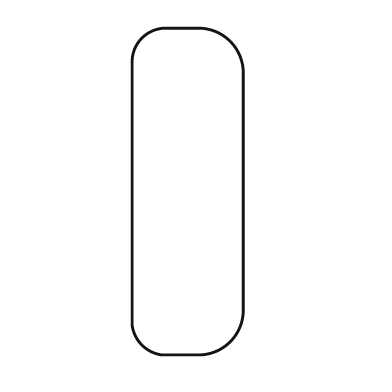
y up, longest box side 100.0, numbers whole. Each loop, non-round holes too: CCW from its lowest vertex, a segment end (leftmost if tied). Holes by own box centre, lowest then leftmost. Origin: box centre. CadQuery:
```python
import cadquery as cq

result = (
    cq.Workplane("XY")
    .moveTo(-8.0, -50.0)
    .lineTo(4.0, -50.0)
    .threePointArc((13.0, -46.0), (17.0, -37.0))
    .lineTo(17.0, 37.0)
    .threePointArc((13.0, 46.0), (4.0, 50.0))
    .lineTo(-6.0, 50.0)
    .threePointArc((-14.0, 47.0), (-17.0, 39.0))
    .lineTo(-17.0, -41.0)
    .threePointArc((-14.0, -47.0), (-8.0, -50.0))
    .close()
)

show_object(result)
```